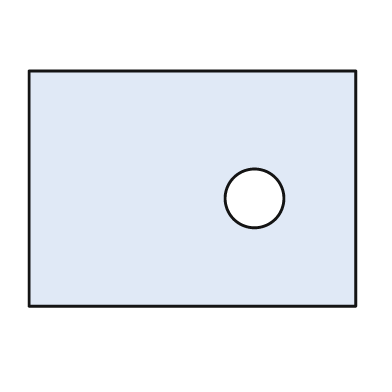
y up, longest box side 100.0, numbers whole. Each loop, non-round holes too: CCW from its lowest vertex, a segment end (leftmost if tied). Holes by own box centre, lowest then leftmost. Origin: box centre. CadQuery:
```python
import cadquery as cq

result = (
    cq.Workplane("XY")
    .moveTo(-50.0, -36.0)
    .lineTo(50.0, -36.0)
    .lineTo(50.0, 36.0)
    .lineTo(-50.0, 36.0)
    .close()
    .moveTo(19.0, -3.0)
    .circle(9.0)
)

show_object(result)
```